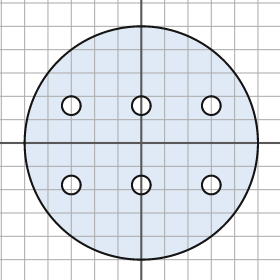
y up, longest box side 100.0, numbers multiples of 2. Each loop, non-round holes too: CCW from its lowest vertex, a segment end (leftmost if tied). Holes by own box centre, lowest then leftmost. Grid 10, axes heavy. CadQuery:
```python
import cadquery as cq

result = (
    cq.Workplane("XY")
    .moveTo(0.0, 0.0)
    .circle(50.0)
    .moveTo(-30.0, -18.0)
    .circle(4.0)
    .moveTo(0.0, -18.0)
    .circle(4.0)
    .moveTo(30.0, -18.0)
    .circle(4.0)
    .moveTo(-30.0, 16.0)
    .circle(4.0)
    .moveTo(0.0, 16.0)
    .circle(4.0)
    .moveTo(30.0, 16.0)
    .circle(4.0)
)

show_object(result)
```